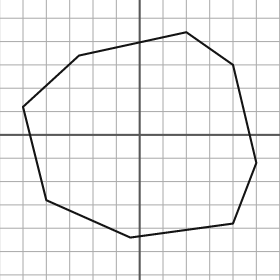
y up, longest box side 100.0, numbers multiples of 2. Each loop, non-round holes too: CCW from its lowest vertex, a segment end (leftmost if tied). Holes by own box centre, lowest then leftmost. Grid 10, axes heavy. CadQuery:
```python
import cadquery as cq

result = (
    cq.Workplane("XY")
    .moveTo(-4.0, -44.0)
    .lineTo(40.0, -38.0)
    .lineTo(50.0, -12.0)
    .lineTo(40.0, 30.0)
    .lineTo(20.0, 44.0)
    .lineTo(-26.0, 34.0)
    .lineTo(-50.0, 12.0)
    .lineTo(-40.0, -28.0)
    .close()
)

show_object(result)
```